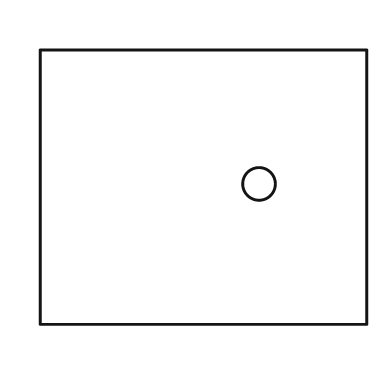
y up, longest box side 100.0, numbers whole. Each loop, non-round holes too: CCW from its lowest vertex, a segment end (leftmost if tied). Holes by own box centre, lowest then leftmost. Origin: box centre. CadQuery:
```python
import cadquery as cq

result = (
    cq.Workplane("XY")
    .moveTo(-50.0, -42.0)
    .lineTo(50.0, -42.0)
    .lineTo(50.0, 42.0)
    .lineTo(-50.0, 42.0)
    .close()
    .moveTo(17.0, 1.0)
    .circle(5.0)
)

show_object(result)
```